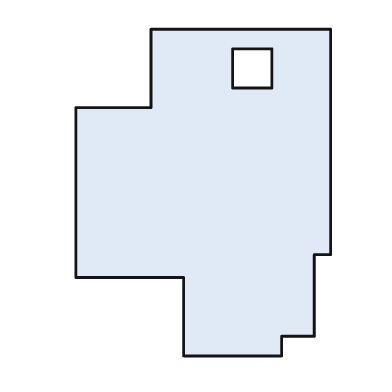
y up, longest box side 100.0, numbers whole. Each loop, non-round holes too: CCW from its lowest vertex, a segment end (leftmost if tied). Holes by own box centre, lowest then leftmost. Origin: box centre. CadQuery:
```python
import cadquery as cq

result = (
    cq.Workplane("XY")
    .moveTo(-6.0, -50.0)
    .lineTo(24.0, -50.0)
    .lineTo(24.0, -44.0)
    .lineTo(34.0, -44.0)
    .lineTo(34.0, -19.0)
    .lineTo(39.0, -19.0)
    .lineTo(39.0, 50.0)
    .lineTo(-16.0, 50.0)
    .lineTo(-16.0, 26.0)
    .lineTo(-39.0, 26.0)
    .lineTo(-39.0, -26.0)
    .lineTo(-6.0, -26.0)
    .close()
    .moveTo(9.0, 32.0)
    .lineTo(21.0, 32.0)
    .lineTo(21.0, 44.0)
    .lineTo(9.0, 44.0)
    .close()
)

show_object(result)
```